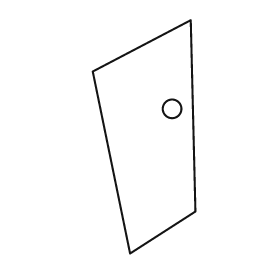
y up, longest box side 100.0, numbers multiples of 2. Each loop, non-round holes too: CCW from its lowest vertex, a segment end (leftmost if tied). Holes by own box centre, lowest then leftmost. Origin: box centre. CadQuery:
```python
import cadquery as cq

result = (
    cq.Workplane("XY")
    .moveTo(-6.0, -50.0)
    .lineTo(22.0, -32.0)
    .lineTo(20.0, 50.0)
    .lineTo(-22.0, 28.0)
    .close()
    .moveTo(12.0, 12.0)
    .circle(4.0)
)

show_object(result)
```